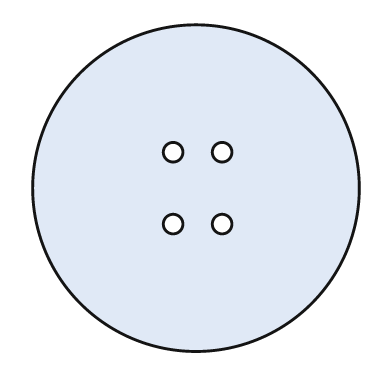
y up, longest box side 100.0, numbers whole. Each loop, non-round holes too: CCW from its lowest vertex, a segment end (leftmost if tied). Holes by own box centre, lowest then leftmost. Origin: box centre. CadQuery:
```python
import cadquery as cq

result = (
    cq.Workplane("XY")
    .moveTo(0.0, 0.0)
    .circle(50.0)
    .moveTo(-7.0, -11.0)
    .circle(3.0)
    .moveTo(8.0, -11.0)
    .circle(3.0)
    .moveTo(-7.0, 11.0)
    .circle(3.0)
    .moveTo(8.0, 11.0)
    .circle(3.0)
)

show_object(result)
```